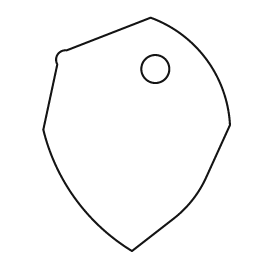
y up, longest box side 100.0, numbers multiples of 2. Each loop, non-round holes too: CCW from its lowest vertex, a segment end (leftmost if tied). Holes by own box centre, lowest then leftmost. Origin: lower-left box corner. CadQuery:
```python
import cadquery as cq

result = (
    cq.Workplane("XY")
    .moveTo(38.0, 0.0)
    .lineTo(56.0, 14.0)
    .threePointArc((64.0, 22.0), (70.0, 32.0))
    .lineTo(80.0, 54.0)
    .threePointArc((70.0, 82.0), (46.0, 100.0))
    .lineTo(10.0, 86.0)
    .threePointArc((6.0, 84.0), (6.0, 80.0))
    .lineTo(0.0, 52.0)
    .threePointArc((14.0, 22.0), (38.0, 0.0))
    .close()
    .moveTo(48.0, 78.0)
    .circle(6.0)
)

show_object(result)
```